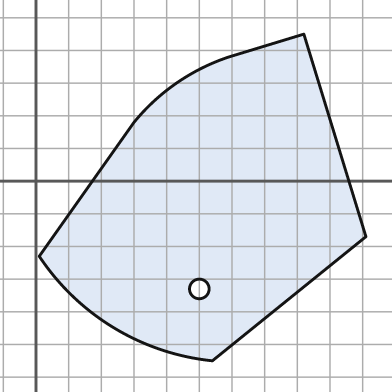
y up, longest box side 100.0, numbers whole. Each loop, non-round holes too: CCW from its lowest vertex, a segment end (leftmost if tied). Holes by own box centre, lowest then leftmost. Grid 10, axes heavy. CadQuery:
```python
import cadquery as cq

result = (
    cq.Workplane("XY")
    .moveTo(54.0, -55.0)
    .lineTo(101.0, -17.0)
    .lineTo(82.0, 45.0)
    .lineTo(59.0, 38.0)
    .threePointArc((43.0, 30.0), (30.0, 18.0))
    .lineTo(1.0, -23.0)
    .threePointArc((24.0, -45.0), (54.0, -55.0))
    .close()
    .moveTo(50.0, -33.0)
    .circle(3.0)
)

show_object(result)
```